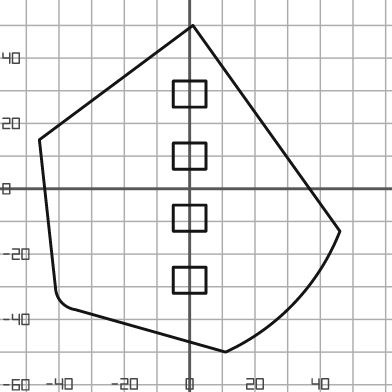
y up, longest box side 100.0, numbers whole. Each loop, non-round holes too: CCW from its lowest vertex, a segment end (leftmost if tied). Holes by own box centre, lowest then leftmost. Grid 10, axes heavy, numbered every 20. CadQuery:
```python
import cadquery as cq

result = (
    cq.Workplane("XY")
    .moveTo(11.0, -50.0)
    .threePointArc((32.0, -35.0), (46.0, -13.0))
    .lineTo(1.0, 50.0)
    .lineTo(-46.0, 15.0)
    .lineTo(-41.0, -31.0)
    .threePointArc((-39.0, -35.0), (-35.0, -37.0))
    .close()
    .moveTo(-5.0, -32.0)
    .lineTo(5.0, -32.0)
    .lineTo(5.0, -24.0)
    .lineTo(-5.0, -24.0)
    .close()
    .moveTo(-5.0, -13.0)
    .lineTo(5.0, -13.0)
    .lineTo(5.0, -5.0)
    .lineTo(-5.0, -5.0)
    .close()
    .moveTo(-5.0, 6.0)
    .lineTo(5.0, 6.0)
    .lineTo(5.0, 14.0)
    .lineTo(-5.0, 14.0)
    .close()
    .moveTo(-5.0, 25.0)
    .lineTo(5.0, 25.0)
    .lineTo(5.0, 33.0)
    .lineTo(-5.0, 33.0)
    .close()
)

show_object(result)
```